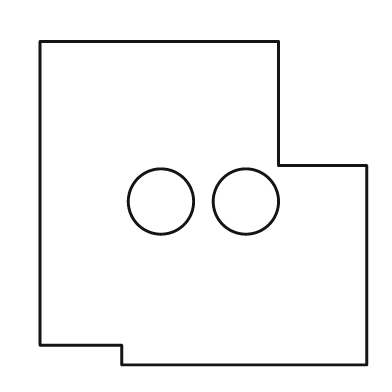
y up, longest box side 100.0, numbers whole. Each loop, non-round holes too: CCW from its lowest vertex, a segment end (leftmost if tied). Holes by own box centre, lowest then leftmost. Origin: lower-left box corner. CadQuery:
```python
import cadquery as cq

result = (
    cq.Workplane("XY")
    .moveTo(25.0, 0.0)
    .lineTo(100.0, 0.0)
    .lineTo(100.0, 61.0)
    .lineTo(73.0, 61.0)
    .lineTo(73.0, 99.0)
    .lineTo(0.0, 99.0)
    .lineTo(0.0, 6.0)
    .lineTo(25.0, 6.0)
    .close()
    .moveTo(37.0, 50.0)
    .circle(10.0)
    .moveTo(63.0, 50.0)
    .circle(10.0)
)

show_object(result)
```